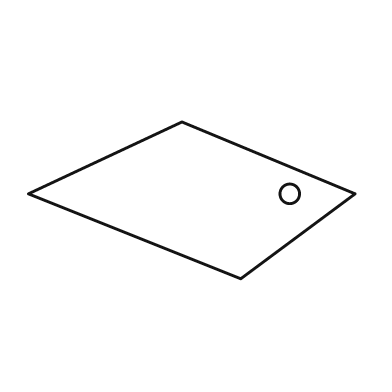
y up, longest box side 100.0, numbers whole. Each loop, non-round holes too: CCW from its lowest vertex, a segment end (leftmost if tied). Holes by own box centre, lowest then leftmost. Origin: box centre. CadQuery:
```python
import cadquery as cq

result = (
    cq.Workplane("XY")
    .moveTo(15.0, -24.0)
    .lineTo(50.0, 2.0)
    .lineTo(-3.0, 24.0)
    .lineTo(-50.0, 2.0)
    .close()
    .moveTo(30.0, 2.0)
    .circle(3.0)
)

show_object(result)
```